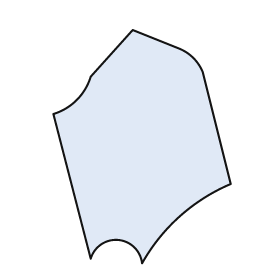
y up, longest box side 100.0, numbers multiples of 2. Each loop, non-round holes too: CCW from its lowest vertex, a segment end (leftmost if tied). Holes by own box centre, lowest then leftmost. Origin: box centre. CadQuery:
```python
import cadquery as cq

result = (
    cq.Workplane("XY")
    .moveTo(0.0, -50.0)
    .threePointArc((16.0, -30.0), (38.0, -16.0))
    .lineTo(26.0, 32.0)
    .threePointArc((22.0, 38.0), (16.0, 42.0))
    .lineTo(-4.0, 50.0)
    .lineTo(-22.0, 30.0)
    .threePointArc((-28.0, 20.0), (-38.0, 14.0))
    .lineTo(-22.0, -48.0)
    .threePointArc((-10.0, -40.0), (0.0, -50.0))
    .close()
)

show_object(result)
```